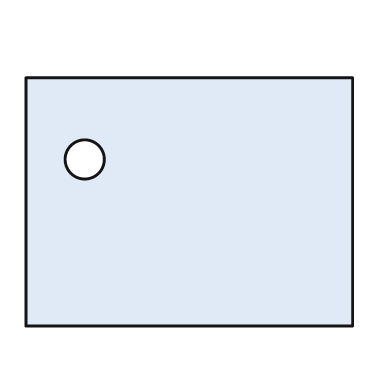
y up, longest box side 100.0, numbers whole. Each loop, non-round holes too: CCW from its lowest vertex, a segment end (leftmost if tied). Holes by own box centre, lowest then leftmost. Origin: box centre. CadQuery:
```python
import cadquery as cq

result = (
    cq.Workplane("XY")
    .moveTo(-50.0, -38.0)
    .lineTo(50.0, -38.0)
    .lineTo(50.0, 38.0)
    .lineTo(-50.0, 38.0)
    .close()
    .moveTo(-32.0, 13.0)
    .circle(6.0)
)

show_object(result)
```